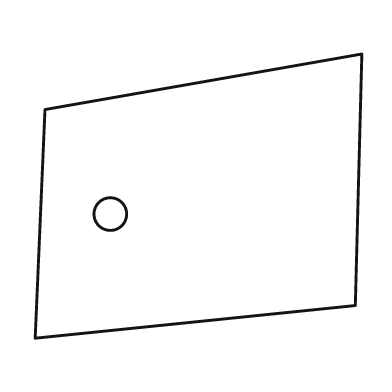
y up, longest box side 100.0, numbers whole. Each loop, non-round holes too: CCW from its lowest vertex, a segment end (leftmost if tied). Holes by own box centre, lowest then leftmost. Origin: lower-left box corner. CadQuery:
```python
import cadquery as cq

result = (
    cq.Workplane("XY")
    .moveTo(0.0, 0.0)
    .lineTo(98.0, 10.0)
    .lineTo(100.0, 87.0)
    .lineTo(3.0, 70.0)
    .close()
    .moveTo(23.0, 38.0)
    .circle(5.0)
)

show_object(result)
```